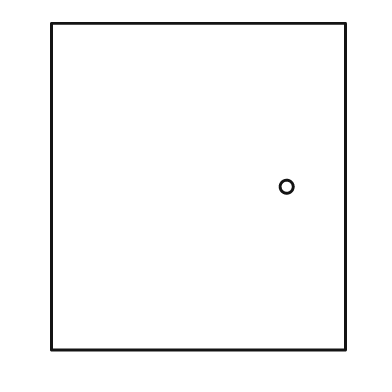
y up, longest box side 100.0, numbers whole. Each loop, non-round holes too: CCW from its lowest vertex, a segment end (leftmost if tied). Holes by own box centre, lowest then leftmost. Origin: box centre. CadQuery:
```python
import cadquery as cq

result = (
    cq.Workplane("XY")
    .moveTo(-45.0, -50.0)
    .lineTo(45.0, -50.0)
    .lineTo(45.0, 50.0)
    .lineTo(-45.0, 50.0)
    .close()
    .moveTo(27.0, 0.0)
    .circle(2.0)
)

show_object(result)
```